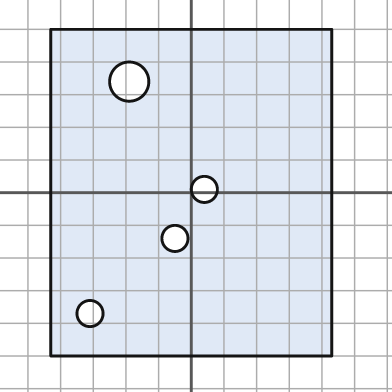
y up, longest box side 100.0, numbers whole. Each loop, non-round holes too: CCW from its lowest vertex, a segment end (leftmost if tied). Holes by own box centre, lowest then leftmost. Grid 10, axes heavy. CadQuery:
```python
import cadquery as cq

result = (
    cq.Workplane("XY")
    .moveTo(-43.0, -50.0)
    .lineTo(43.0, -50.0)
    .lineTo(43.0, 50.0)
    .lineTo(-43.0, 50.0)
    .close()
    .moveTo(-31.0, -37.0)
    .circle(4.0)
    .moveTo(-5.0, -14.0)
    .circle(4.0)
    .moveTo(4.0, 1.0)
    .circle(4.0)
    .moveTo(-19.0, 34.0)
    .circle(6.0)
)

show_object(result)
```